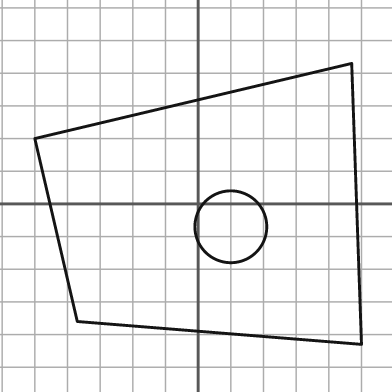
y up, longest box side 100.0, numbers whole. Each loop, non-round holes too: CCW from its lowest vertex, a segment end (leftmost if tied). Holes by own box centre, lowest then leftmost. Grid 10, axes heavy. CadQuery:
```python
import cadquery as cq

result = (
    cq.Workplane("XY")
    .moveTo(50.0, -43.0)
    .lineTo(47.0, 43.0)
    .lineTo(-50.0, 20.0)
    .lineTo(-37.0, -36.0)
    .close()
    .moveTo(10.0, -7.0)
    .circle(11.0)
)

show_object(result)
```